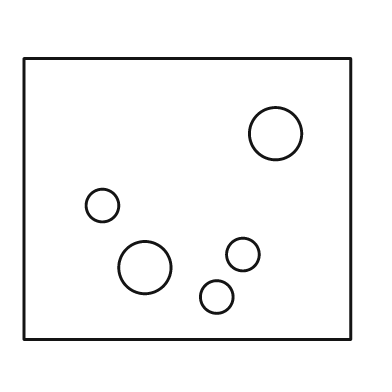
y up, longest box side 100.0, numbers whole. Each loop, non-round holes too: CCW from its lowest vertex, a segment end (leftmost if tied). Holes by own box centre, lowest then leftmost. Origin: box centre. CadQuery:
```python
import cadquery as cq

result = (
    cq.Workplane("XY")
    .moveTo(-50.0, -43.0)
    .lineTo(50.0, -43.0)
    .lineTo(50.0, 43.0)
    .lineTo(-50.0, 43.0)
    .close()
    .moveTo(9.0, -30.0)
    .circle(5.0)
    .moveTo(-13.0, -21.0)
    .circle(8.0)
    .moveTo(17.0, -17.0)
    .circle(5.0)
    .moveTo(-26.0, -2.0)
    .circle(5.0)
    .moveTo(27.0, 20.0)
    .circle(8.0)
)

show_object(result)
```